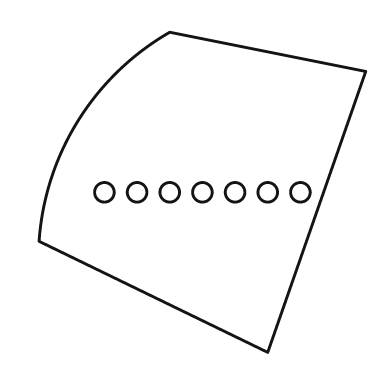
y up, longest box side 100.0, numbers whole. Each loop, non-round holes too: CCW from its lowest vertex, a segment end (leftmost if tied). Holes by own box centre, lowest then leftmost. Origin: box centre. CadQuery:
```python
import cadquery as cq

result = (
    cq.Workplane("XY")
    .moveTo(20.0, -49.0)
    .lineTo(50.0, 37.0)
    .lineTo(-10.0, 49.0)
    .threePointArc((-38.0, 22.0), (-50.0, -15.0))
    .close()
    .moveTo(-30.0, 0.0)
    .circle(3.0)
    .moveTo(-20.0, 0.0)
    .circle(3.0)
    .moveTo(-10.0, 0.0)
    .circle(3.0)
    .moveTo(0.0, 0.0)
    .circle(3.0)
    .moveTo(10.0, 0.0)
    .circle(3.0)
    .moveTo(20.0, 0.0)
    .circle(3.0)
    .moveTo(30.0, 0.0)
    .circle(3.0)
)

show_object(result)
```